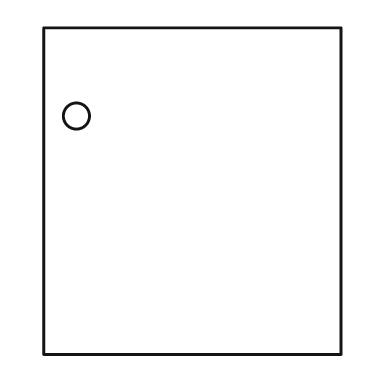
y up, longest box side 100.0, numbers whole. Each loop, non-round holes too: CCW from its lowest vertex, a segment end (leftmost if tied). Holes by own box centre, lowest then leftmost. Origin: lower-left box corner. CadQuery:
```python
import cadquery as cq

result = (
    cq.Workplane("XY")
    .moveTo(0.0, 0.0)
    .lineTo(91.0, 0.0)
    .lineTo(91.0, 100.0)
    .lineTo(0.0, 100.0)
    .close()
    .moveTo(10.0, 73.0)
    .circle(4.0)
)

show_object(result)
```